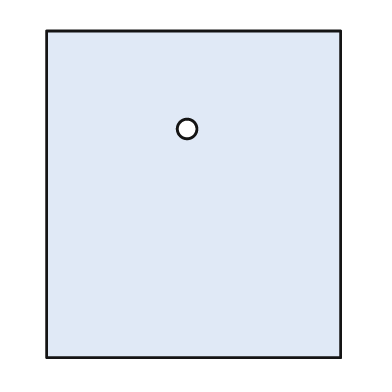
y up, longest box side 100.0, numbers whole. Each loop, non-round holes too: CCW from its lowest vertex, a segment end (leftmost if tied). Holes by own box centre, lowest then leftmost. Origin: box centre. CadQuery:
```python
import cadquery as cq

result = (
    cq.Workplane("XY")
    .moveTo(-45.0, -50.0)
    .lineTo(45.0, -50.0)
    .lineTo(45.0, 50.0)
    .lineTo(-45.0, 50.0)
    .close()
    .moveTo(-2.0, 20.0)
    .circle(3.0)
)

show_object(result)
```